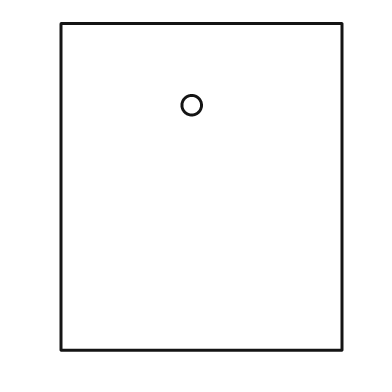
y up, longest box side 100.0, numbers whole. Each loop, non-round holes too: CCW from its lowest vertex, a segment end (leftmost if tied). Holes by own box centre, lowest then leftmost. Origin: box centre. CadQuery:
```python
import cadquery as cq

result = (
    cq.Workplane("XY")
    .moveTo(-43.0, -50.0)
    .lineTo(43.0, -50.0)
    .lineTo(43.0, 50.0)
    .lineTo(-43.0, 50.0)
    .close()
    .moveTo(-3.0, 25.0)
    .circle(3.0)
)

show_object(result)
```